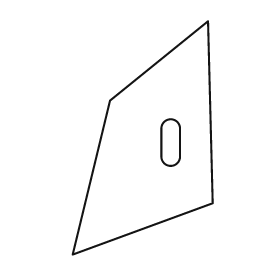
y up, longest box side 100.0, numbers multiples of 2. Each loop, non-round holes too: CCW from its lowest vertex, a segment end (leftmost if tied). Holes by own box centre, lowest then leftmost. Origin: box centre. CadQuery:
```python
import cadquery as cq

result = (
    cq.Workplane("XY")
    .moveTo(-30.0, -50.0)
    .lineTo(30.0, -28.0)
    .lineTo(28.0, 50.0)
    .lineTo(-14.0, 16.0)
    .close()
    .moveTo(8.0, -8.0)
    .threePointArc((12.0, -12.0), (16.0, -8.0))
    .lineTo(16.0, 4.0)
    .threePointArc((12.0, 8.0), (8.0, 4.0))
    .close()
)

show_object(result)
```